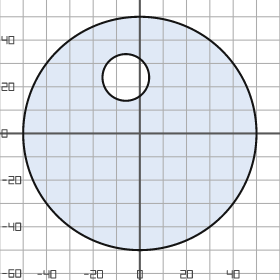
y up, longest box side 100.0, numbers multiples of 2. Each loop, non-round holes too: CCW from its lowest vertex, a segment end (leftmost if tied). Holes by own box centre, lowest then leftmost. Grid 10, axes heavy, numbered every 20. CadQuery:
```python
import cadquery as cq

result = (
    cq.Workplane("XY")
    .moveTo(0.0, 0.0)
    .circle(50.0)
    .moveTo(-6.0, 24.0)
    .circle(10.0)
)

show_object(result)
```